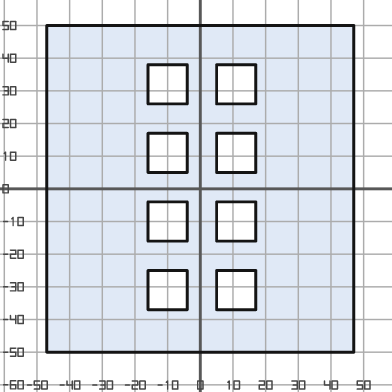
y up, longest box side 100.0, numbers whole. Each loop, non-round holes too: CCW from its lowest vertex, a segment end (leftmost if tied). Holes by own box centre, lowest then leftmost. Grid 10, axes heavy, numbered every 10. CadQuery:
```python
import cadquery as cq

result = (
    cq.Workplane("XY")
    .moveTo(-47.0, -50.0)
    .lineTo(47.0, -50.0)
    .lineTo(47.0, 50.0)
    .lineTo(-47.0, 50.0)
    .close()
    .moveTo(-16.0, -37.0)
    .lineTo(-4.0, -37.0)
    .lineTo(-4.0, -25.0)
    .lineTo(-16.0, -25.0)
    .close()
    .moveTo(5.0, -37.0)
    .lineTo(17.0, -37.0)
    .lineTo(17.0, -25.0)
    .lineTo(5.0, -25.0)
    .close()
    .moveTo(-16.0, -16.0)
    .lineTo(-4.0, -16.0)
    .lineTo(-4.0, -4.0)
    .lineTo(-16.0, -4.0)
    .close()
    .moveTo(5.0, -16.0)
    .lineTo(17.0, -16.0)
    .lineTo(17.0, -4.0)
    .lineTo(5.0, -4.0)
    .close()
    .moveTo(-16.0, 5.0)
    .lineTo(-4.0, 5.0)
    .lineTo(-4.0, 17.0)
    .lineTo(-16.0, 17.0)
    .close()
    .moveTo(5.0, 5.0)
    .lineTo(17.0, 5.0)
    .lineTo(17.0, 17.0)
    .lineTo(5.0, 17.0)
    .close()
    .moveTo(-16.0, 26.0)
    .lineTo(-4.0, 26.0)
    .lineTo(-4.0, 38.0)
    .lineTo(-16.0, 38.0)
    .close()
    .moveTo(5.0, 26.0)
    .lineTo(17.0, 26.0)
    .lineTo(17.0, 38.0)
    .lineTo(5.0, 38.0)
    .close()
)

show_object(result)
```